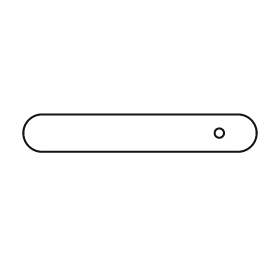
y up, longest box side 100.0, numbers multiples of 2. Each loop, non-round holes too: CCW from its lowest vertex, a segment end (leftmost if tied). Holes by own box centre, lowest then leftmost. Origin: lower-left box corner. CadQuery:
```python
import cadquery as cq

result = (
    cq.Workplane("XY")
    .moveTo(8.0, 0.0)
    .lineTo(92.0, 0.0)
    .threePointArc((100.0, 8.0), (92.0, 16.0))
    .lineTo(8.0, 16.0)
    .threePointArc((0.0, 8.0), (8.0, 0.0))
    .close()
    .moveTo(84.0, 8.0)
    .circle(2.0)
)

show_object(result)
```